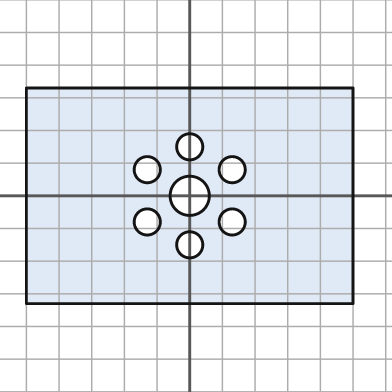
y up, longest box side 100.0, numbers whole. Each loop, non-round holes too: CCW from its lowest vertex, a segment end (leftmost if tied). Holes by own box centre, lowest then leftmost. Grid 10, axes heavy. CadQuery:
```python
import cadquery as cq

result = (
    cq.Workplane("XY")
    .moveTo(-50.0, -33.0)
    .lineTo(50.0, -33.0)
    .lineTo(50.0, 33.0)
    .lineTo(-50.0, 33.0)
    .close()
    .moveTo(0.0, -15.0)
    .circle(4.0)
    .moveTo(-13.0, -8.0)
    .circle(4.0)
    .moveTo(13.0, -8.0)
    .circle(4.0)
    .moveTo(0.0, 0.0)
    .circle(6.0)
    .moveTo(-13.0, 8.0)
    .circle(4.0)
    .moveTo(13.0, 8.0)
    .circle(4.0)
    .moveTo(0.0, 15.0)
    .circle(4.0)
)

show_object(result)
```